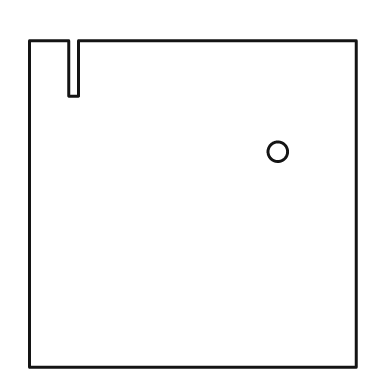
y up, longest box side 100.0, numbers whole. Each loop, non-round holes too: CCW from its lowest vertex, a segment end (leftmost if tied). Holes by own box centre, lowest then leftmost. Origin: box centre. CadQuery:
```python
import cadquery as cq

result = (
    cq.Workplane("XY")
    .moveTo(-50.0, -50.0)
    .lineTo(50.0, -50.0)
    .lineTo(50.0, 50.0)
    .lineTo(-35.0, 50.0)
    .lineTo(-35.0, 33.0)
    .lineTo(-38.0, 33.0)
    .lineTo(-38.0, 50.0)
    .lineTo(-50.0, 50.0)
    .close()
    .moveTo(26.0, 16.0)
    .circle(3.0)
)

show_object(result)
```